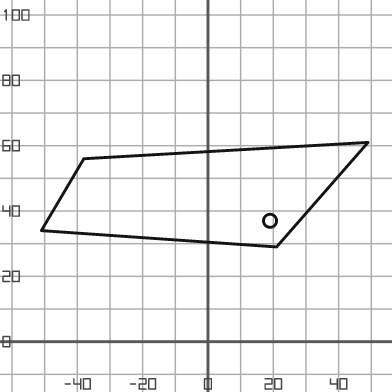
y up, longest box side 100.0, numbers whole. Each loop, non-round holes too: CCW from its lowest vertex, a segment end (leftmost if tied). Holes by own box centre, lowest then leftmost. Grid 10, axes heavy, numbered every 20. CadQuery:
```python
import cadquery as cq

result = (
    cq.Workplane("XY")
    .moveTo(21.0, 29.0)
    .lineTo(49.0, 61.0)
    .lineTo(-38.0, 56.0)
    .lineTo(-51.0, 34.0)
    .close()
    .moveTo(19.0, 37.0)
    .circle(2.0)
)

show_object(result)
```